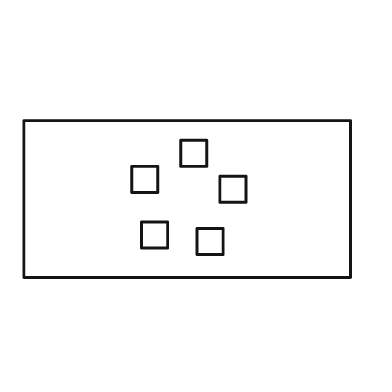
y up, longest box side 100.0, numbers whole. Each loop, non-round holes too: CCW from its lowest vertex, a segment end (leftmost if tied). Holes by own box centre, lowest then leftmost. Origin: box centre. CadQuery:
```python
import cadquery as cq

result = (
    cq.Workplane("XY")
    .moveTo(-50.0, -24.0)
    .lineTo(50.0, -24.0)
    .lineTo(50.0, 24.0)
    .lineTo(-50.0, 24.0)
    .close()
    .moveTo(3.0, -17.0)
    .lineTo(11.0, -17.0)
    .lineTo(11.0, -9.0)
    .lineTo(3.0, -9.0)
    .close()
    .moveTo(-14.0, -15.0)
    .lineTo(-6.0, -15.0)
    .lineTo(-6.0, -7.0)
    .lineTo(-14.0, -7.0)
    .close()
    .moveTo(10.0, -1.0)
    .lineTo(18.0, -1.0)
    .lineTo(18.0, 7.0)
    .lineTo(10.0, 7.0)
    .close()
    .moveTo(-17.0, 2.0)
    .lineTo(-9.0, 2.0)
    .lineTo(-9.0, 10.0)
    .lineTo(-17.0, 10.0)
    .close()
    .moveTo(-2.0, 10.0)
    .lineTo(6.0, 10.0)
    .lineTo(6.0, 18.0)
    .lineTo(-2.0, 18.0)
    .close()
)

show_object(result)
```